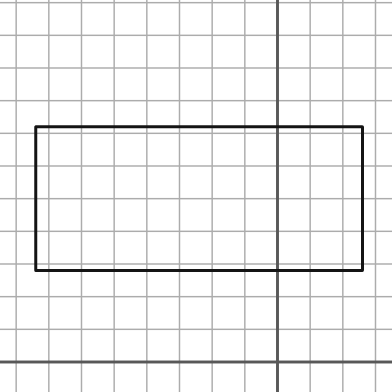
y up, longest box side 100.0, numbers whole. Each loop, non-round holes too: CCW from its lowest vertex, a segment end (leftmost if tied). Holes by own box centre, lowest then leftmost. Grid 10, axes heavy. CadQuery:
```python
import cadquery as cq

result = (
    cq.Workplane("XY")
    .moveTo(-74.0, 28.0)
    .lineTo(26.0, 28.0)
    .lineTo(26.0, 72.0)
    .lineTo(-74.0, 72.0)
    .close()
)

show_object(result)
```